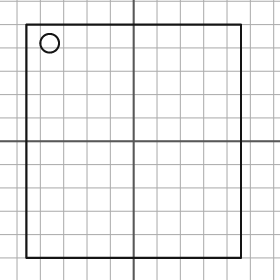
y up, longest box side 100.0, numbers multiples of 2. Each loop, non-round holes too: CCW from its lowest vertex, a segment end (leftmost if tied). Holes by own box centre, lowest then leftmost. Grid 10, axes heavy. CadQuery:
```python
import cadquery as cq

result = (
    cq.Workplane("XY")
    .moveTo(-46.0, -50.0)
    .lineTo(46.0, -50.0)
    .lineTo(46.0, 50.0)
    .lineTo(-46.0, 50.0)
    .close()
    .moveTo(-36.0, 42.0)
    .circle(4.0)
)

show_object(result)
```